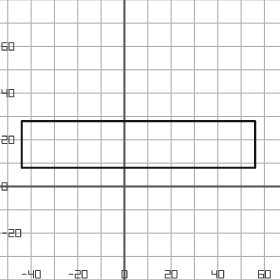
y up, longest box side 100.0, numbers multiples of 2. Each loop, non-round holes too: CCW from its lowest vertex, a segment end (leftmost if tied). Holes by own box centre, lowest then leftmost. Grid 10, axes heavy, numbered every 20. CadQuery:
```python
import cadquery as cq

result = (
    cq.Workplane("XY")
    .moveTo(-44.0, 8.0)
    .lineTo(56.0, 8.0)
    .lineTo(56.0, 28.0)
    .lineTo(-44.0, 28.0)
    .close()
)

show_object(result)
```